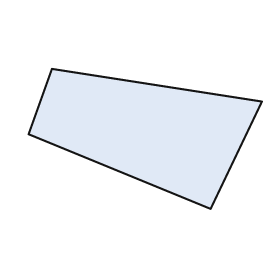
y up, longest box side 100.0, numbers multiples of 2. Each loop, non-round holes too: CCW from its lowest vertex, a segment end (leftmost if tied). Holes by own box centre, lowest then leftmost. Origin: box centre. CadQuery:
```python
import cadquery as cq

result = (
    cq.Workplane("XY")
    .moveTo(28.0, -30.0)
    .lineTo(50.0, 16.0)
    .lineTo(-40.0, 30.0)
    .lineTo(-50.0, 2.0)
    .close()
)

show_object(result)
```